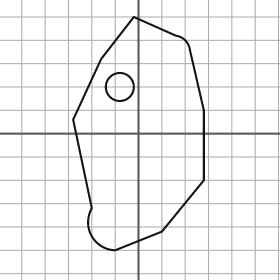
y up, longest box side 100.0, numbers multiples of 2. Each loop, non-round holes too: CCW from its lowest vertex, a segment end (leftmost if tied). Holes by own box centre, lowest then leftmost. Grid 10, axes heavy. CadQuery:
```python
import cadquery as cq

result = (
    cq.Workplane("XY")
    .moveTo(-10.0, -50.0)
    .lineTo(10.0, -42.0)
    .lineTo(28.0, -20.0)
    .lineTo(28.0, 10.0)
    .lineTo(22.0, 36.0)
    .threePointArc((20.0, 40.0), (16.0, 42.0))
    .lineTo(-2.0, 50.0)
    .lineTo(-16.0, 32.0)
    .lineTo(-28.0, 6.0)
    .lineTo(-20.0, -32.0)
    .threePointArc((-20.0, -44.0), (-10.0, -50.0))
    .close()
    .moveTo(-8.0, 20.0)
    .circle(6.0)
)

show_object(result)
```